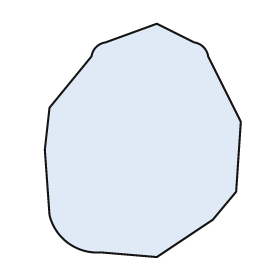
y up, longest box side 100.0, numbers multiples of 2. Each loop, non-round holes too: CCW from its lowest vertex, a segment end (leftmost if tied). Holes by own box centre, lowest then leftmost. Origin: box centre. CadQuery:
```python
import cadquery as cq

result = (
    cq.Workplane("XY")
    .moveTo(6.0, -50.0)
    .lineTo(30.0, -34.0)
    .lineTo(40.0, -22.0)
    .lineTo(42.0, 8.0)
    .lineTo(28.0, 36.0)
    .threePointArc((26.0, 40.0), (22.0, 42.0))
    .lineTo(6.0, 50.0)
    .lineTo(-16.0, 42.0)
    .threePointArc((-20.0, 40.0), (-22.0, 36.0))
    .lineTo(-40.0, 14.0)
    .lineTo(-42.0, -4.0)
    .lineTo(-40.0, -32.0)
    .threePointArc((-32.0, -44.0), (-18.0, -48.0))
    .close()
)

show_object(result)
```